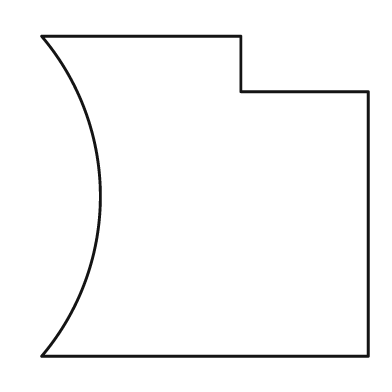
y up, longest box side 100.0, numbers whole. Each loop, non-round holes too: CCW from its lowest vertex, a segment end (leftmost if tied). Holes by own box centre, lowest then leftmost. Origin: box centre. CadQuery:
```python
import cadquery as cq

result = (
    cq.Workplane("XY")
    .moveTo(-50.0, -49.0)
    .lineTo(50.0, -49.0)
    .lineTo(50.0, 32.0)
    .lineTo(11.0, 32.0)
    .lineTo(11.0, 49.0)
    .lineTo(-50.0, 49.0)
    .threePointArc((-32.0, 0.0), (-50.0, -49.0))
    .close()
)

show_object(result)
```